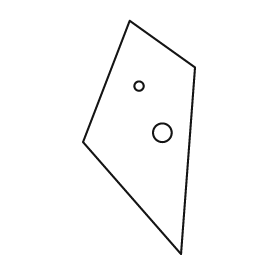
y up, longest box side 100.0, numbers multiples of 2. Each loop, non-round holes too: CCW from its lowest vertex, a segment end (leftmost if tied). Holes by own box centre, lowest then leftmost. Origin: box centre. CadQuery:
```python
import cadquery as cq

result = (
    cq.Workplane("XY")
    .moveTo(18.0, -50.0)
    .lineTo(24.0, 30.0)
    .lineTo(-4.0, 50.0)
    .lineTo(-24.0, -2.0)
    .close()
    .moveTo(10.0, 2.0)
    .circle(4.0)
    .moveTo(0.0, 22.0)
    .circle(2.0)
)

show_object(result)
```